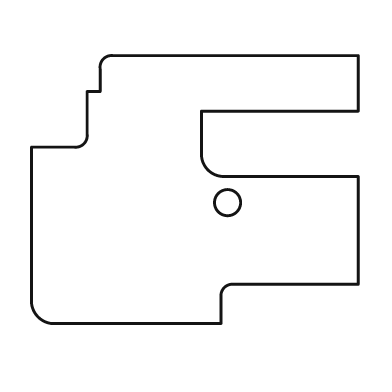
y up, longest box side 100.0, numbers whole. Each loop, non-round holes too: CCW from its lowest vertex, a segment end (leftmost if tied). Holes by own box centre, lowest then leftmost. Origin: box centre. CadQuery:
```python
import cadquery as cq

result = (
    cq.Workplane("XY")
    .moveTo(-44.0, -41.0)
    .lineTo(8.0, -41.0)
    .lineTo(8.0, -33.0)
    .threePointArc((9.0, -30.0), (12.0, -29.0))
    .lineTo(50.0, -29.0)
    .lineTo(50.0, 4.0)
    .lineTo(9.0, 4.0)
    .threePointArc((4.0, 6.0), (2.0, 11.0))
    .lineTo(2.0, 24.0)
    .lineTo(50.0, 24.0)
    .lineTo(50.0, 41.0)
    .lineTo(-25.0, 41.0)
    .threePointArc((-28.0, 40.0), (-29.0, 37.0))
    .lineTo(-29.0, 30.0)
    .lineTo(-33.0, 30.0)
    .lineTo(-33.0, 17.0)
    .threePointArc((-34.0, 14.0), (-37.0, 13.0))
    .lineTo(-50.0, 13.0)
    .lineTo(-50.0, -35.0)
    .threePointArc((-48.0, -39.0), (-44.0, -41.0))
    .close()
    .moveTo(10.0, -4.0)
    .circle(4.0)
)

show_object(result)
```